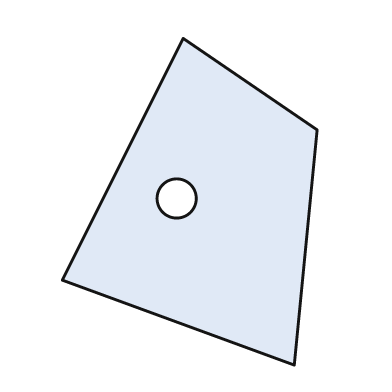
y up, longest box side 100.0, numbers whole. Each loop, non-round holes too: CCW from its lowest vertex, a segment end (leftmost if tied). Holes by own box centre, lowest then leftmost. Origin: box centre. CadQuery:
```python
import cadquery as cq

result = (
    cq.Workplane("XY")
    .moveTo(32.0, -50.0)
    .lineTo(39.0, 22.0)
    .lineTo(-2.0, 50.0)
    .lineTo(-39.0, -24.0)
    .close()
    .moveTo(-4.0, 1.0)
    .circle(6.0)
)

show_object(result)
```